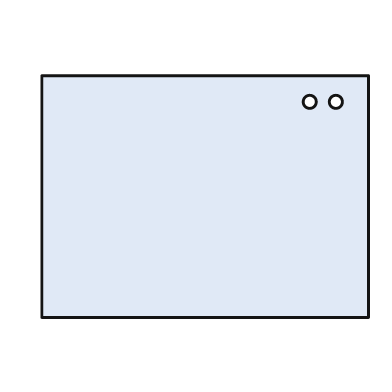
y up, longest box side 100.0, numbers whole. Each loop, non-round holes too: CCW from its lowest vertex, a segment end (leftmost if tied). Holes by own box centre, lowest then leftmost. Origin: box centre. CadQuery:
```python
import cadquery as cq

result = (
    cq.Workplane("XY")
    .moveTo(-50.0, -37.0)
    .lineTo(50.0, -37.0)
    .lineTo(50.0, 37.0)
    .lineTo(-50.0, 37.0)
    .close()
    .moveTo(32.0, 29.0)
    .circle(2.0)
    .moveTo(40.0, 29.0)
    .circle(2.0)
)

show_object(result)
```